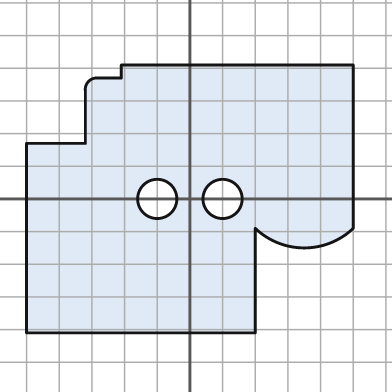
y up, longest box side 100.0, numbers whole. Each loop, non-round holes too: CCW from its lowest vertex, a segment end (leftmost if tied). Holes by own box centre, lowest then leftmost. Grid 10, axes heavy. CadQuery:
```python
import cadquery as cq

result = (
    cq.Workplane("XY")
    .moveTo(-50.0, -41.0)
    .lineTo(20.0, -41.0)
    .lineTo(20.0, -9.0)
    .threePointArc((35.0, -15.0), (50.0, -9.0))
    .lineTo(50.0, 41.0)
    .lineTo(-21.0, 41.0)
    .lineTo(-21.0, 37.0)
    .lineTo(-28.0, 37.0)
    .threePointArc((-31.0, 36.0), (-32.0, 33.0))
    .lineTo(-32.0, 17.0)
    .lineTo(-50.0, 17.0)
    .close()
    .moveTo(-10.0, 0.0)
    .circle(6.0)
    .moveTo(10.0, 0.0)
    .circle(6.0)
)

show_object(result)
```